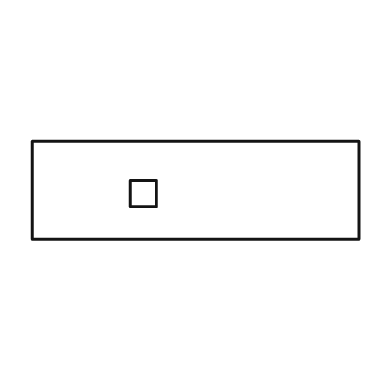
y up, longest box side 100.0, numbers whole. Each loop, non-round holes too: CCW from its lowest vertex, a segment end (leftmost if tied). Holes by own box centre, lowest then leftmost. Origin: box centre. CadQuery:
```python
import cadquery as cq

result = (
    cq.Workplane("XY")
    .moveTo(-50.0, -15.0)
    .lineTo(50.0, -15.0)
    .lineTo(50.0, 15.0)
    .lineTo(-50.0, 15.0)
    .close()
    .moveTo(-20.0, -5.0)
    .lineTo(-12.0, -5.0)
    .lineTo(-12.0, 3.0)
    .lineTo(-20.0, 3.0)
    .close()
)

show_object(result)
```